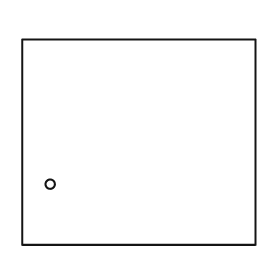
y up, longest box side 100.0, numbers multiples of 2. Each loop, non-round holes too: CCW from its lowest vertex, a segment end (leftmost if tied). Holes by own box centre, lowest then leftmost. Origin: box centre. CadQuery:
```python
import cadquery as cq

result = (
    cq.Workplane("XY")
    .moveTo(-50.0, -44.0)
    .lineTo(50.0, -44.0)
    .lineTo(50.0, 44.0)
    .lineTo(-50.0, 44.0)
    .close()
    .moveTo(-38.0, -18.0)
    .circle(2.0)
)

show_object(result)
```